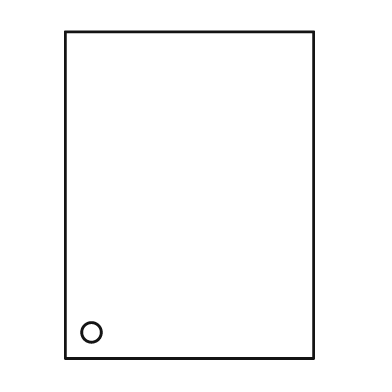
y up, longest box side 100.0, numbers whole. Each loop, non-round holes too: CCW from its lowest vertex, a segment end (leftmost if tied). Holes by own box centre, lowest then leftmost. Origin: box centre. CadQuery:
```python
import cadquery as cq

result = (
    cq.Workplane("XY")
    .moveTo(-38.0, -50.0)
    .lineTo(38.0, -50.0)
    .lineTo(38.0, 50.0)
    .lineTo(-38.0, 50.0)
    .close()
    .moveTo(-30.0, -42.0)
    .circle(3.0)
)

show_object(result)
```